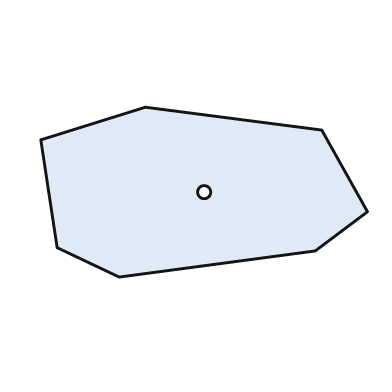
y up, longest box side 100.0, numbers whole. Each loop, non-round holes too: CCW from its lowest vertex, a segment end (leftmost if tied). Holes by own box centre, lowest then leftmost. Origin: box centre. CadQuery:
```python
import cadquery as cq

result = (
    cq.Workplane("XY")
    .moveTo(-26.0, -26.0)
    .lineTo(34.0, -18.0)
    .lineTo(50.0, -6.0)
    .lineTo(36.0, 19.0)
    .lineTo(-18.0, 26.0)
    .lineTo(-50.0, 16.0)
    .lineTo(-45.0, -17.0)
    .close()
    .moveTo(0.0, 0.0)
    .circle(2.0)
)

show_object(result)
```